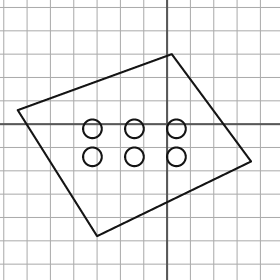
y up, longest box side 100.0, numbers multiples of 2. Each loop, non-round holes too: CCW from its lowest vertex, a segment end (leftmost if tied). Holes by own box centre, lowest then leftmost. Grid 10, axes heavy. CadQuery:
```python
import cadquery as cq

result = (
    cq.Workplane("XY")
    .moveTo(-30.0, -48.0)
    .lineTo(36.0, -16.0)
    .lineTo(2.0, 30.0)
    .lineTo(-64.0, 6.0)
    .close()
    .moveTo(-32.0, -14.0)
    .circle(4.0)
    .moveTo(-14.0, -14.0)
    .circle(4.0)
    .moveTo(4.0, -14.0)
    .circle(4.0)
    .moveTo(-32.0, -2.0)
    .circle(4.0)
    .moveTo(-14.0, -2.0)
    .circle(4.0)
    .moveTo(4.0, -2.0)
    .circle(4.0)
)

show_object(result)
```